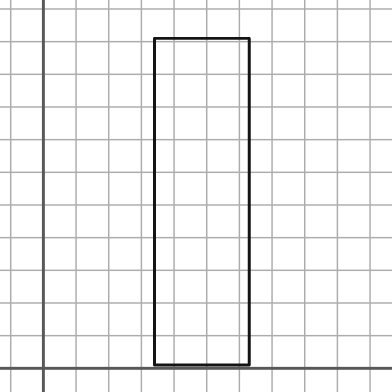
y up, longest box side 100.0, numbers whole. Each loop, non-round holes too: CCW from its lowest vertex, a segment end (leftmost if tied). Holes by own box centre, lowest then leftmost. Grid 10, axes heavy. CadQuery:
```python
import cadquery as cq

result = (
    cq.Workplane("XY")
    .moveTo(34.0, 1.0)
    .lineTo(63.0, 1.0)
    .lineTo(63.0, 101.0)
    .lineTo(34.0, 101.0)
    .close()
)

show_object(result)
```